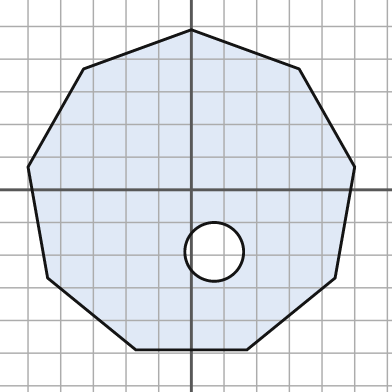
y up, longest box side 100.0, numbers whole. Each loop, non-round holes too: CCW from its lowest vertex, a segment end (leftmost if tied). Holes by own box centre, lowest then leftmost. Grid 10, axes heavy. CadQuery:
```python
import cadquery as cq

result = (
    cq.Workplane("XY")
    .moveTo(-17.0, -49.0)
    .lineTo(17.0, -49.0)
    .lineTo(44.0, -27.0)
    .lineTo(50.0, 7.0)
    .lineTo(33.0, 37.0)
    .lineTo(0.0, 49.0)
    .lineTo(-33.0, 37.0)
    .lineTo(-50.0, 7.0)
    .lineTo(-44.0, -27.0)
    .close()
    .moveTo(7.0, -19.0)
    .circle(9.0)
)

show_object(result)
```